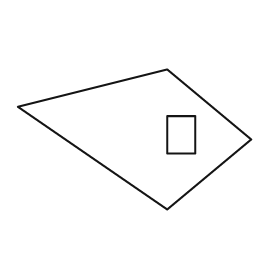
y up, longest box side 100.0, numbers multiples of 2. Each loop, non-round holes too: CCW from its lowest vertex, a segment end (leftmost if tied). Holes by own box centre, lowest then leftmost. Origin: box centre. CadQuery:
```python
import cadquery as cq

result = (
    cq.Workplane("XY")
    .moveTo(14.0, -30.0)
    .lineTo(50.0, 0.0)
    .lineTo(14.0, 30.0)
    .lineTo(-50.0, 14.0)
    .close()
    .moveTo(14.0, -6.0)
    .lineTo(26.0, -6.0)
    .lineTo(26.0, 10.0)
    .lineTo(14.0, 10.0)
    .close()
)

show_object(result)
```